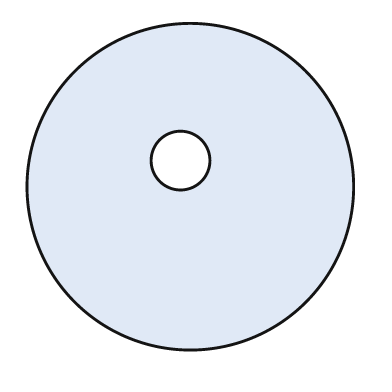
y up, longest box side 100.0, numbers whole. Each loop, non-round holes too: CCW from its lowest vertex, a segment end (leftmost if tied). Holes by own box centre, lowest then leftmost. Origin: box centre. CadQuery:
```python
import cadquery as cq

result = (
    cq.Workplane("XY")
    .moveTo(0.0, 0.0)
    .circle(50.0)
    .moveTo(-3.0, 8.0)
    .circle(9.0)
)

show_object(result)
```